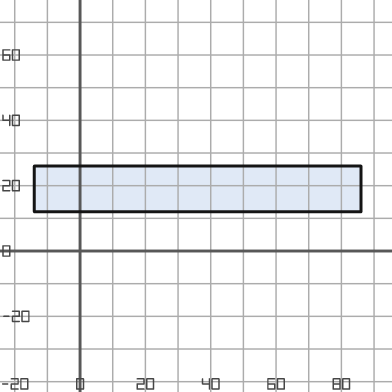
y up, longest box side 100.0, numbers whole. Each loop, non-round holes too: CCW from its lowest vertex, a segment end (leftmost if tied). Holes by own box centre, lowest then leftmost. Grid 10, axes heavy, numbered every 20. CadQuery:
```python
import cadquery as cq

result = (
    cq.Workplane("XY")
    .moveTo(-14.0, 12.0)
    .lineTo(86.0, 12.0)
    .lineTo(86.0, 26.0)
    .lineTo(-14.0, 26.0)
    .close()
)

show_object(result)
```